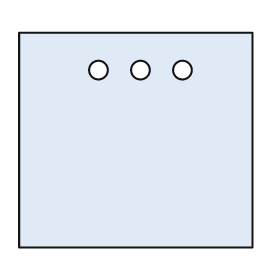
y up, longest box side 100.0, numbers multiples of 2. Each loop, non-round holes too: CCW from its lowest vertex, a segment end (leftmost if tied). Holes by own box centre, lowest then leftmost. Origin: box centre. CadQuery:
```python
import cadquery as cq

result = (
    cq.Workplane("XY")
    .moveTo(-50.0, -46.0)
    .lineTo(50.0, -46.0)
    .lineTo(50.0, 46.0)
    .lineTo(-50.0, 46.0)
    .close()
    .moveTo(-16.0, 30.0)
    .circle(4.0)
    .moveTo(2.0, 30.0)
    .circle(4.0)
    .moveTo(20.0, 30.0)
    .circle(4.0)
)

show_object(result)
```